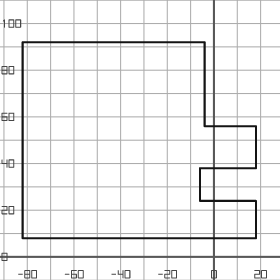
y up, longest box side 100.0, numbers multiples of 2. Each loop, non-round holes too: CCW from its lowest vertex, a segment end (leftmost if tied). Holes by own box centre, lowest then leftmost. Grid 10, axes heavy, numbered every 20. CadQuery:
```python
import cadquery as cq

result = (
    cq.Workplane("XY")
    .moveTo(-82.0, 8.0)
    .lineTo(18.0, 8.0)
    .lineTo(18.0, 24.0)
    .lineTo(-6.0, 24.0)
    .lineTo(-6.0, 38.0)
    .lineTo(18.0, 38.0)
    .lineTo(18.0, 56.0)
    .lineTo(-4.0, 56.0)
    .lineTo(-4.0, 92.0)
    .lineTo(-82.0, 92.0)
    .close()
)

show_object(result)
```